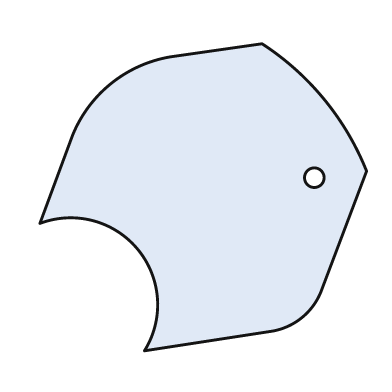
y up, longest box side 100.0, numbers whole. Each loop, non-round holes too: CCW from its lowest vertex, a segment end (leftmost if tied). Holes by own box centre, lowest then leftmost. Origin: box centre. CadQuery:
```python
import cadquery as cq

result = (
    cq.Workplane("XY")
    .moveTo(-18.0, -47.0)
    .lineTo(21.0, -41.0)
    .threePointArc((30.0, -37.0), (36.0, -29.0))
    .lineTo(50.0, 8.0)
    .threePointArc((37.0, 30.0), (18.0, 47.0))
    .lineTo(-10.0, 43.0)
    .threePointArc((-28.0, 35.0), (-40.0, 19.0))
    .lineTo(-50.0, -8.0)
    .threePointArc((-20.0, -16.0), (-18.0, -47.0))
    .close()
    .moveTo(34.0, 6.0)
    .circle(3.0)
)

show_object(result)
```